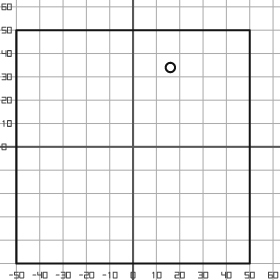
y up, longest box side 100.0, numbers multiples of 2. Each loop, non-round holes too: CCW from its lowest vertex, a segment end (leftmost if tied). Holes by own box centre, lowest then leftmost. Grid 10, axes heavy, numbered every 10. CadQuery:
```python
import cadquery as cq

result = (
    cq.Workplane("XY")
    .moveTo(-50.0, -50.0)
    .lineTo(50.0, -50.0)
    .lineTo(50.0, 50.0)
    .lineTo(-50.0, 50.0)
    .close()
    .moveTo(16.0, 34.0)
    .circle(2.0)
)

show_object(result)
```